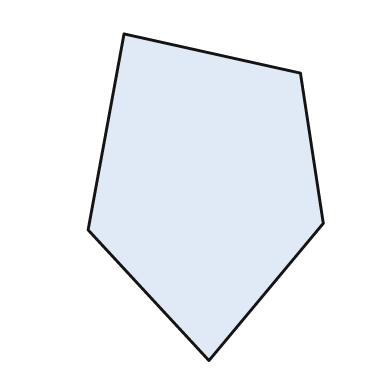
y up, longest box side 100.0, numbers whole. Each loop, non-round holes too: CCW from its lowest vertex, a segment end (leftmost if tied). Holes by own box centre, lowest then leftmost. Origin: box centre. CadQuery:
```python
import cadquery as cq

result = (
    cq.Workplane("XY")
    .moveTo(1.0, -50.0)
    .lineTo(36.0, -8.0)
    .lineTo(29.0, 38.0)
    .lineTo(-25.0, 50.0)
    .lineTo(-36.0, -10.0)
    .close()
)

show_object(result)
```